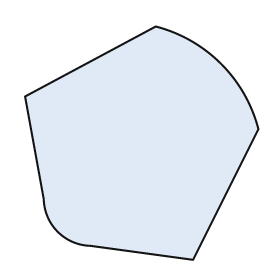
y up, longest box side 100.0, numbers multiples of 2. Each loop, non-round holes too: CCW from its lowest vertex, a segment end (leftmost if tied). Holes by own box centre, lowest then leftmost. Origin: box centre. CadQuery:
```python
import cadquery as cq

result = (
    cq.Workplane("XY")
    .moveTo(22.0, -50.0)
    .lineTo(50.0, 6.0)
    .threePointArc((34.0, 34.0), (6.0, 50.0))
    .lineTo(-50.0, 20.0)
    .lineTo(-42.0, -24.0)
    .threePointArc((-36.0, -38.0), (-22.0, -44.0))
    .close()
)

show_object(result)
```